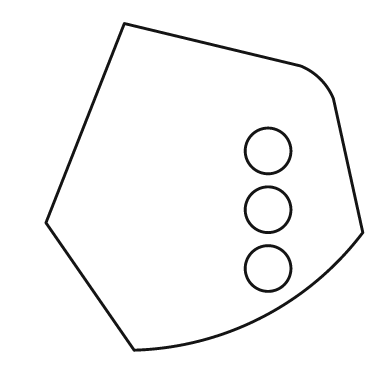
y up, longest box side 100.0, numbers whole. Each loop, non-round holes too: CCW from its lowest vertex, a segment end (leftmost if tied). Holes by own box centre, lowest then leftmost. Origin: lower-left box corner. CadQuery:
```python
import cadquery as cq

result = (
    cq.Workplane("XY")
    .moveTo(27.0, 0.0)
    .threePointArc((66.0, 10.0), (97.0, 36.0))
    .lineTo(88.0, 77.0)
    .threePointArc((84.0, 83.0), (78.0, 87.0))
    .lineTo(24.0, 100.0)
    .lineTo(0.0, 39.0)
    .close()
    .moveTo(68.0, 25.0)
    .circle(7.0)
    .moveTo(68.0, 43.0)
    .circle(7.0)
    .moveTo(68.0, 61.0)
    .circle(7.0)
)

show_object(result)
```